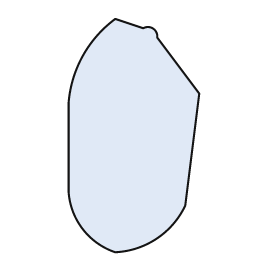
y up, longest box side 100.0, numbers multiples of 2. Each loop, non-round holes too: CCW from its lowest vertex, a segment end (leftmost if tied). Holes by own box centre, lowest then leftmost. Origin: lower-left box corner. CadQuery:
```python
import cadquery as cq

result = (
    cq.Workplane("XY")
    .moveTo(20.0, 0.0)
    .threePointArc((38.0, 6.0), (50.0, 20.0))
    .lineTo(56.0, 68.0)
    .lineTo(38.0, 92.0)
    .threePointArc((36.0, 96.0), (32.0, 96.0))
    .lineTo(20.0, 100.0)
    .threePointArc((6.0, 84.0), (0.0, 64.0))
    .lineTo(0.0, 26.0)
    .threePointArc((6.0, 10.0), (20.0, 0.0))
    .close()
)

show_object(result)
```